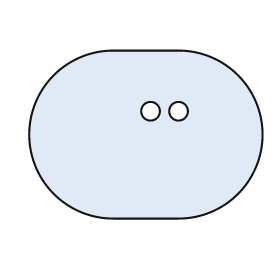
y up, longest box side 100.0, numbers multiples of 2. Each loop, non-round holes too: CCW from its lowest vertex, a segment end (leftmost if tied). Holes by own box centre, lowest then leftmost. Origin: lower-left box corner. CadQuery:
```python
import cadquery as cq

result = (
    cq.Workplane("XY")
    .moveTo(36.0, 0.0)
    .lineTo(64.0, 0.0)
    .threePointArc((100.0, 36.0), (64.0, 72.0))
    .lineTo(36.0, 72.0)
    .threePointArc((0.0, 36.0), (36.0, 0.0))
    .close()
    .moveTo(52.0, 46.0)
    .circle(4.0)
    .moveTo(64.0, 46.0)
    .circle(4.0)
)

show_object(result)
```